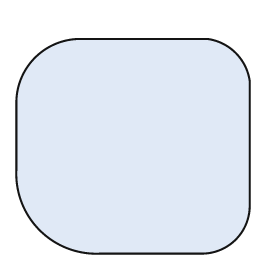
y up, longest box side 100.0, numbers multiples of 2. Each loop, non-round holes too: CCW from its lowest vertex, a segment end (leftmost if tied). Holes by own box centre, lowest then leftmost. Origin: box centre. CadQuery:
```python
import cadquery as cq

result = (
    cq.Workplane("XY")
    .moveTo(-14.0, -46.0)
    .lineTo(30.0, -46.0)
    .threePointArc((44.0, -40.0), (50.0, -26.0))
    .lineTo(50.0, 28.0)
    .threePointArc((44.0, 40.0), (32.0, 46.0))
    .lineTo(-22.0, 46.0)
    .threePointArc((-42.0, 38.0), (-50.0, 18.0))
    .lineTo(-50.0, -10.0)
    .threePointArc((-40.0, -36.0), (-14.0, -46.0))
    .close()
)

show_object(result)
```